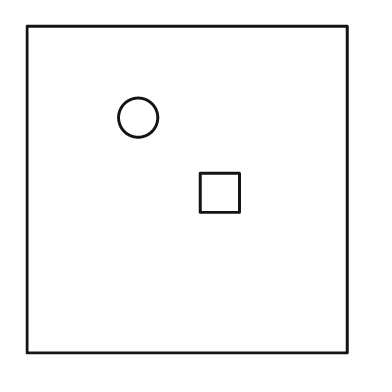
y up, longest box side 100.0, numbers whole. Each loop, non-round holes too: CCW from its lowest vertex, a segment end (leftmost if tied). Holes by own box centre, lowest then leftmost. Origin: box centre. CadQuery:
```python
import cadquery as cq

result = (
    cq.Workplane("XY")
    .moveTo(-49.0, -50.0)
    .lineTo(49.0, -50.0)
    .lineTo(49.0, 50.0)
    .lineTo(-49.0, 50.0)
    .close()
    .moveTo(4.0, -7.0)
    .lineTo(16.0, -7.0)
    .lineTo(16.0, 5.0)
    .lineTo(4.0, 5.0)
    .close()
    .moveTo(-15.0, 22.0)
    .circle(6.0)
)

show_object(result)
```